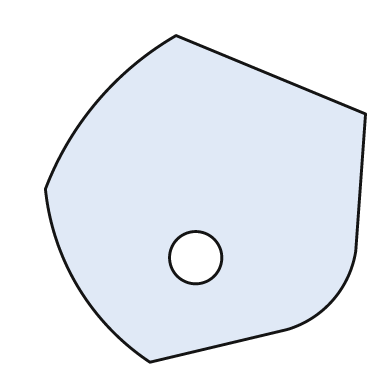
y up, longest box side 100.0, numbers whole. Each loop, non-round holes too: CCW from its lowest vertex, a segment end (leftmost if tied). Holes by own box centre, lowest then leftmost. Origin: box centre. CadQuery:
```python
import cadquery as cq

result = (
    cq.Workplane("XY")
    .moveTo(-17.0, -50.0)
    .lineTo(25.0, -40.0)
    .threePointArc((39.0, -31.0), (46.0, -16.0))
    .lineTo(49.0, 26.0)
    .lineTo(-9.0, 50.0)
    .threePointArc((-33.0, 30.0), (-49.0, 3.0))
    .threePointArc((-39.0, -27.0), (-17.0, -50.0))
    .close()
    .moveTo(-3.0, -18.0)
    .circle(8.0)
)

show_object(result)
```